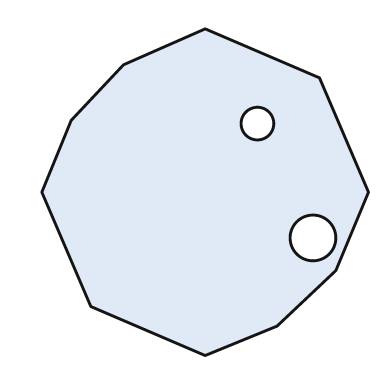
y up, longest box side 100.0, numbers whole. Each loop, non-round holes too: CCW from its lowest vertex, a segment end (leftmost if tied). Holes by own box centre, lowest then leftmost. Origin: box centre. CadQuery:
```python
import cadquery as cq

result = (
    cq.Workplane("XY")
    .moveTo(0.0, -50.0)
    .lineTo(22.0, -41.0)
    .lineTo(40.0, -24.0)
    .lineTo(50.0, 0.0)
    .lineTo(35.0, 35.0)
    .lineTo(0.0, 50.0)
    .lineTo(-25.0, 39.0)
    .lineTo(-41.0, 22.0)
    .lineTo(-50.0, 0.0)
    .lineTo(-35.0, -35.0)
    .close()
    .moveTo(33.0, -14.0)
    .circle(7.0)
    .moveTo(16.0, 21.0)
    .circle(5.0)
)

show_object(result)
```